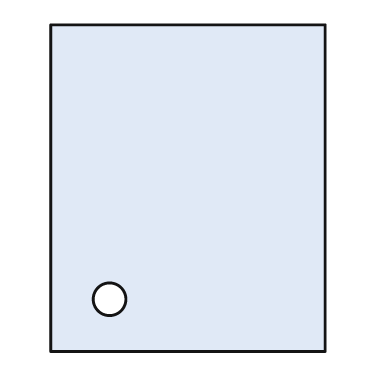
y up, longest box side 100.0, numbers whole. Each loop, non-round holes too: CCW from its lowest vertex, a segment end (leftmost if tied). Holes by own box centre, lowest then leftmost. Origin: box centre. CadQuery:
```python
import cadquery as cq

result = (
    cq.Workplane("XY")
    .moveTo(-42.0, -50.0)
    .lineTo(42.0, -50.0)
    .lineTo(42.0, 50.0)
    .lineTo(-42.0, 50.0)
    .close()
    .moveTo(-24.0, -34.0)
    .circle(5.0)
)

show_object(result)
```